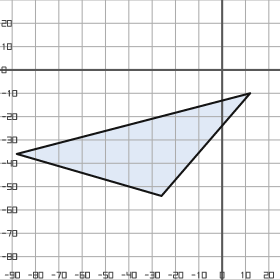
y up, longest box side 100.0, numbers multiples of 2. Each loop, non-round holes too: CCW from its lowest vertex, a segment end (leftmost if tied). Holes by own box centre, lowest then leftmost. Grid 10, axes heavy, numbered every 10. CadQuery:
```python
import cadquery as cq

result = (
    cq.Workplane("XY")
    .moveTo(-26.0, -54.0)
    .lineTo(12.0, -10.0)
    .lineTo(-88.0, -36.0)
    .close()
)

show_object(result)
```